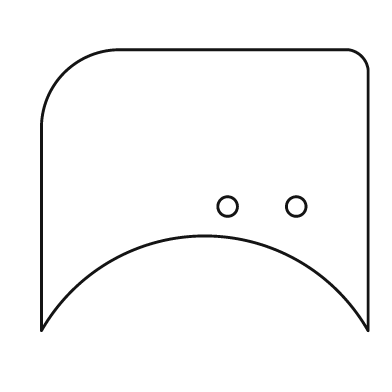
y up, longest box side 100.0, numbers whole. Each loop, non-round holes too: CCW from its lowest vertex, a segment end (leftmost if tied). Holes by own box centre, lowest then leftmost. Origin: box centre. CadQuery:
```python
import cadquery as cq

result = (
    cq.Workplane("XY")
    .moveTo(-50.0, -43.0)
    .threePointArc((0.0, -14.0), (50.0, -43.0))
    .lineTo(50.0, 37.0)
    .threePointArc((48.0, 41.0), (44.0, 43.0))
    .lineTo(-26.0, 43.0)
    .threePointArc((-43.0, 36.0), (-50.0, 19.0))
    .close()
    .moveTo(7.0, -5.0)
    .circle(3.0)
    .moveTo(28.0, -5.0)
    .circle(3.0)
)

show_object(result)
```